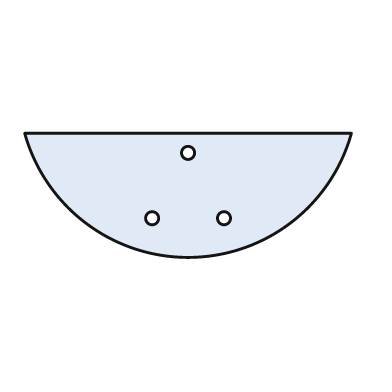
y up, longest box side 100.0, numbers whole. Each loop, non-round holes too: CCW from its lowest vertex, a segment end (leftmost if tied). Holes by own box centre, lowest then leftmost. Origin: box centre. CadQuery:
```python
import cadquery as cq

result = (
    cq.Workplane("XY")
    .moveTo(-50.0, 19.0)
    .threePointArc((0.0, -19.0), (50.0, 19.0))
    .close()
    .moveTo(-11.0, -7.0)
    .circle(2.0)
    .moveTo(11.0, -7.0)
    .circle(2.0)
    .moveTo(0.0, 13.0)
    .circle(2.0)
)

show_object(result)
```